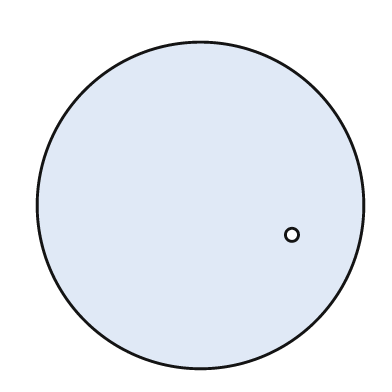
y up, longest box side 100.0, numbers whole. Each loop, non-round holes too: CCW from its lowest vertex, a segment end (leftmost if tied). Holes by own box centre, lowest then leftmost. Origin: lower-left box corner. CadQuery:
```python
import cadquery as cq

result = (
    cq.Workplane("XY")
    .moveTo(50.0, 50.0)
    .circle(50.0)
    .moveTo(78.0, 41.0)
    .circle(2.0)
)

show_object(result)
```